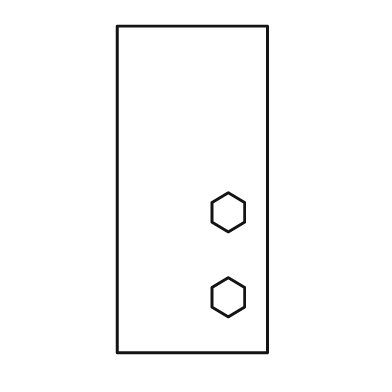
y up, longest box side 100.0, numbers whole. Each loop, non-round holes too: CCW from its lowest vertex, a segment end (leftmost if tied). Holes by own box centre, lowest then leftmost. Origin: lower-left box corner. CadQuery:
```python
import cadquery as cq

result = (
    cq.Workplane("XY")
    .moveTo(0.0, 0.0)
    .lineTo(46.0, 0.0)
    .lineTo(46.0, 100.0)
    .lineTo(0.0, 100.0)
    .close()
    .moveTo(34.0, 11.0)
    .lineTo(39.0, 14.0)
    .lineTo(39.0, 20.0)
    .lineTo(34.0, 23.0)
    .lineTo(29.0, 20.0)
    .lineTo(29.0, 14.0)
    .close()
    .moveTo(34.0, 37.0)
    .lineTo(39.0, 40.0)
    .lineTo(39.0, 46.0)
    .lineTo(34.0, 49.0)
    .lineTo(29.0, 46.0)
    .lineTo(29.0, 40.0)
    .close()
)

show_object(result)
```